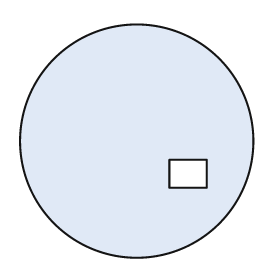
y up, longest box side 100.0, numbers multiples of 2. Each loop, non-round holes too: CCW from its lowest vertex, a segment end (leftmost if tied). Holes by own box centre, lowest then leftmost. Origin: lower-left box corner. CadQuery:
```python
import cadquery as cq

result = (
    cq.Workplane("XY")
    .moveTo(50.0, 50.0)
    .circle(50.0)
    .moveTo(64.0, 30.0)
    .lineTo(80.0, 30.0)
    .lineTo(80.0, 42.0)
    .lineTo(64.0, 42.0)
    .close()
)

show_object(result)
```